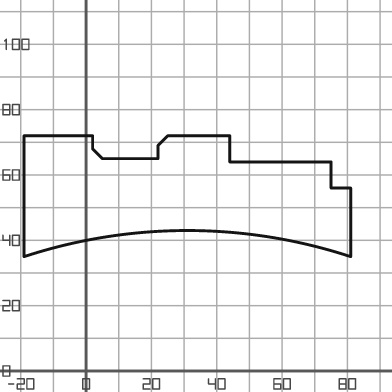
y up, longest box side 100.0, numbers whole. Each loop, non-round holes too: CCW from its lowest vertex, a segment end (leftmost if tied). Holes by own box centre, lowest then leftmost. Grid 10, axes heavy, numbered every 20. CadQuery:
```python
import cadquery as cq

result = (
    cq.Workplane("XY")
    .moveTo(-19.0, 35.0)
    .threePointArc((31.0, 43.0), (81.0, 35.0))
    .lineTo(81.0, 56.0)
    .lineTo(75.0, 56.0)
    .lineTo(75.0, 64.0)
    .lineTo(44.0, 64.0)
    .lineTo(44.0, 72.0)
    .lineTo(25.0, 72.0)
    .lineTo(22.0, 69.0)
    .lineTo(22.0, 65.0)
    .lineTo(5.0, 65.0)
    .lineTo(2.0, 68.0)
    .lineTo(2.0, 72.0)
    .lineTo(-19.0, 72.0)
    .close()
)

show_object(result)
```